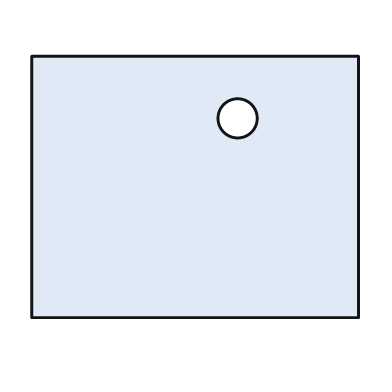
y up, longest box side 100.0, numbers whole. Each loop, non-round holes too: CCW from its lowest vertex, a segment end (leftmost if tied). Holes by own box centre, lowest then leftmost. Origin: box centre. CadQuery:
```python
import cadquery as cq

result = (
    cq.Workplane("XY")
    .moveTo(-50.0, -40.0)
    .lineTo(50.0, -40.0)
    .lineTo(50.0, 40.0)
    .lineTo(-50.0, 40.0)
    .close()
    .moveTo(13.0, 21.0)
    .circle(6.0)
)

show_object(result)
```